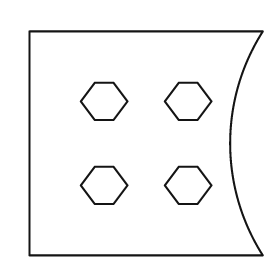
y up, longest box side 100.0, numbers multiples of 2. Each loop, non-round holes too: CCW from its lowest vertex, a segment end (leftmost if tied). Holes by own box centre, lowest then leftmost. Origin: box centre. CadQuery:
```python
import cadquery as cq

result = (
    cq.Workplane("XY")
    .moveTo(-50.0, -48.0)
    .lineTo(50.0, -48.0)
    .threePointArc((36.0, 0.0), (50.0, 48.0))
    .lineTo(-50.0, 48.0)
    .close()
    .moveTo(-22.0, -26.0)
    .lineTo(-14.0, -26.0)
    .lineTo(-8.0, -18.0)
    .lineTo(-14.0, -10.0)
    .lineTo(-22.0, -10.0)
    .lineTo(-28.0, -18.0)
    .close()
    .moveTo(14.0, -26.0)
    .lineTo(22.0, -26.0)
    .lineTo(28.0, -18.0)
    .lineTo(22.0, -10.0)
    .lineTo(14.0, -10.0)
    .lineTo(8.0, -18.0)
    .close()
    .moveTo(-22.0, 10.0)
    .lineTo(-14.0, 10.0)
    .lineTo(-8.0, 18.0)
    .lineTo(-14.0, 26.0)
    .lineTo(-22.0, 26.0)
    .lineTo(-28.0, 18.0)
    .close()
    .moveTo(14.0, 10.0)
    .lineTo(22.0, 10.0)
    .lineTo(28.0, 18.0)
    .lineTo(22.0, 26.0)
    .lineTo(14.0, 26.0)
    .lineTo(8.0, 18.0)
    .close()
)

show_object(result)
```